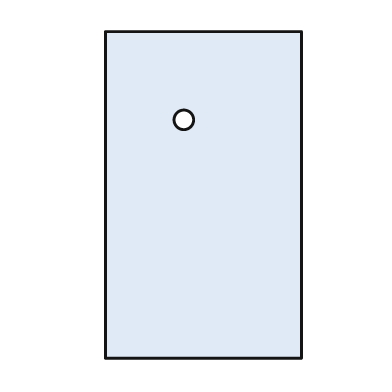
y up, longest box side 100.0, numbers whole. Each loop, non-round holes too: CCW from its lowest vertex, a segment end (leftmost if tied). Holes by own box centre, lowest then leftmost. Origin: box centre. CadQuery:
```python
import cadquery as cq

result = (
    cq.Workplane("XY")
    .moveTo(-30.0, -50.0)
    .lineTo(30.0, -50.0)
    .lineTo(30.0, 50.0)
    .lineTo(-30.0, 50.0)
    .close()
    .moveTo(-6.0, 23.0)
    .circle(3.0)
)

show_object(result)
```